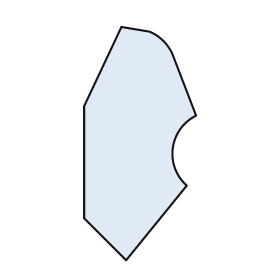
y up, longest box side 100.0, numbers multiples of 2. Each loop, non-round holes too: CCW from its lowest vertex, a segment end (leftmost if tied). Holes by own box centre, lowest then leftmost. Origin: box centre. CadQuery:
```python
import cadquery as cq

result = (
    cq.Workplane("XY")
    .moveTo(-6.0, -50.0)
    .lineTo(20.0, -18.0)
    .threePointArc((14.0, -2.0), (24.0, 12.0))
    .lineTo(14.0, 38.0)
    .threePointArc((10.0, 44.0), (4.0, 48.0))
    .lineTo(-8.0, 50.0)
    .lineTo(-24.0, 16.0)
    .lineTo(-24.0, -32.0)
    .close()
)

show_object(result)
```